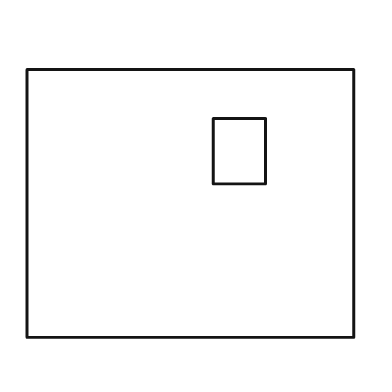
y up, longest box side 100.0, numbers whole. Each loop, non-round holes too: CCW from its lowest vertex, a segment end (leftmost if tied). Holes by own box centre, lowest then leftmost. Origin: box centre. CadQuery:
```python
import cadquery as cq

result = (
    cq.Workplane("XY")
    .moveTo(-50.0, -41.0)
    .lineTo(50.0, -41.0)
    .lineTo(50.0, 41.0)
    .lineTo(-50.0, 41.0)
    .close()
    .moveTo(7.0, 6.0)
    .lineTo(23.0, 6.0)
    .lineTo(23.0, 26.0)
    .lineTo(7.0, 26.0)
    .close()
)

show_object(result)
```